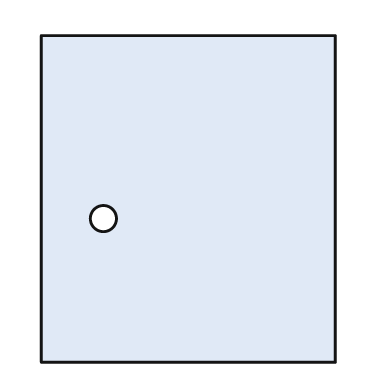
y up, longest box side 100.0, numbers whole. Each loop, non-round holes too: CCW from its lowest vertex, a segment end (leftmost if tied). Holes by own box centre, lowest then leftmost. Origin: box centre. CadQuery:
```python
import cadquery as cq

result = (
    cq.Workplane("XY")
    .moveTo(-45.0, -50.0)
    .lineTo(45.0, -50.0)
    .lineTo(45.0, 50.0)
    .lineTo(-45.0, 50.0)
    .close()
    .moveTo(-26.0, -6.0)
    .circle(4.0)
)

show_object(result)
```